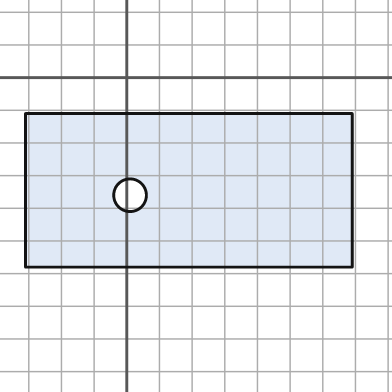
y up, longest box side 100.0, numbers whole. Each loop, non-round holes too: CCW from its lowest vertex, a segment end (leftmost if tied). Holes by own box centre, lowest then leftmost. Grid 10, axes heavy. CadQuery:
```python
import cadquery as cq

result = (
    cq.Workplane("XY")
    .moveTo(-31.0, -58.0)
    .lineTo(69.0, -58.0)
    .lineTo(69.0, -11.0)
    .lineTo(-31.0, -11.0)
    .close()
    .moveTo(1.0, -36.0)
    .circle(5.0)
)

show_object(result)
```